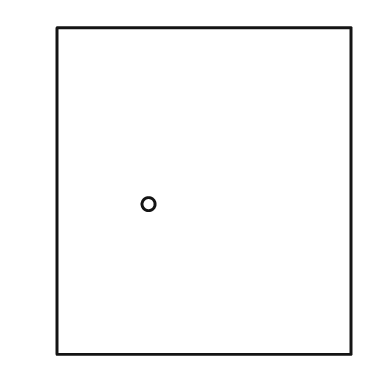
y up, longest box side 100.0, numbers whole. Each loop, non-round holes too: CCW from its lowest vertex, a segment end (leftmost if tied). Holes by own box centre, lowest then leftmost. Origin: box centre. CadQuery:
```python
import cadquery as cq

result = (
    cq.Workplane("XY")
    .moveTo(-45.0, -50.0)
    .lineTo(45.0, -50.0)
    .lineTo(45.0, 50.0)
    .lineTo(-45.0, 50.0)
    .close()
    .moveTo(-17.0, -4.0)
    .circle(2.0)
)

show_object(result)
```